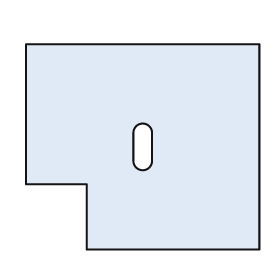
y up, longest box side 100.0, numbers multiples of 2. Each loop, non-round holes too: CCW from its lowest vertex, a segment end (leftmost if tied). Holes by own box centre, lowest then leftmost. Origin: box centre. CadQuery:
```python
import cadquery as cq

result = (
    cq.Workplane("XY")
    .moveTo(-24.0, -44.0)
    .lineTo(50.0, -44.0)
    .lineTo(50.0, 44.0)
    .lineTo(-50.0, 44.0)
    .lineTo(-50.0, -16.0)
    .lineTo(-24.0, -16.0)
    .close()
    .moveTo(-4.0, -6.0)
    .threePointArc((0.0, -10.0), (4.0, -6.0))
    .lineTo(4.0, 6.0)
    .threePointArc((0.0, 10.0), (-4.0, 6.0))
    .close()
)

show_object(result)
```